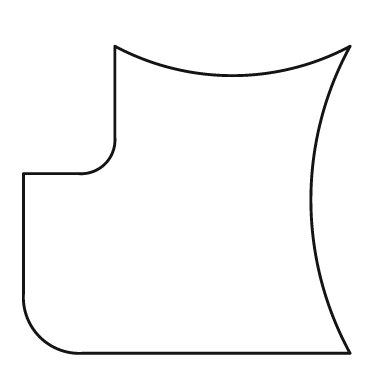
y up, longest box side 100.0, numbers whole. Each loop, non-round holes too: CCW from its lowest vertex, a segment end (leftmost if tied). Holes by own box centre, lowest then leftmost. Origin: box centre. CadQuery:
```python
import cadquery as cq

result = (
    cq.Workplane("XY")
    .moveTo(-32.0, -47.0)
    .lineTo(50.0, -47.0)
    .threePointArc((38.0, 0.0), (50.0, 47.0))
    .threePointArc((14.0, 38.0), (-22.0, 47.0))
    .lineTo(-22.0, 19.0)
    .threePointArc((-25.0, 11.0), (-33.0, 8.0))
    .lineTo(-50.0, 8.0)
    .lineTo(-50.0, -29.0)
    .threePointArc((-45.0, -42.0), (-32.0, -47.0))
    .close()
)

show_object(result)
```